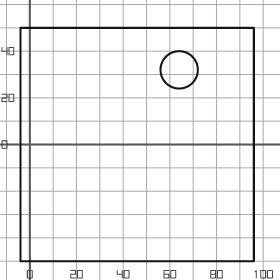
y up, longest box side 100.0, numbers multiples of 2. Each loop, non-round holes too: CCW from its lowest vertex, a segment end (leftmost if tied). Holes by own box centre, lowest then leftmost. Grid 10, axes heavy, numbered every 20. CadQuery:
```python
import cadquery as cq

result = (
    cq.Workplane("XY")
    .moveTo(-4.0, -50.0)
    .lineTo(96.0, -50.0)
    .lineTo(96.0, 50.0)
    .lineTo(-4.0, 50.0)
    .close()
    .moveTo(64.0, 32.0)
    .circle(8.0)
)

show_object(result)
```